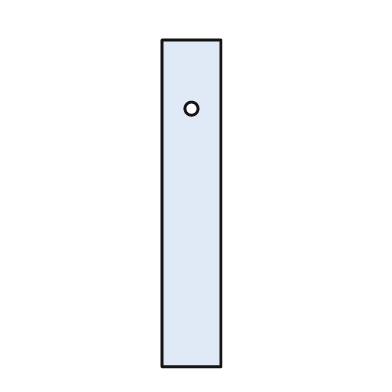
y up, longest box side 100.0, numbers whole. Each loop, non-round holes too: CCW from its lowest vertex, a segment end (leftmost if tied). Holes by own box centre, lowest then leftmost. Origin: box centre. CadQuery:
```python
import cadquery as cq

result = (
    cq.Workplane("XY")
    .moveTo(-9.0, -50.0)
    .lineTo(9.0, -50.0)
    .lineTo(9.0, 50.0)
    .lineTo(-9.0, 50.0)
    .close()
    .moveTo(0.0, 29.0)
    .circle(2.0)
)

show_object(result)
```